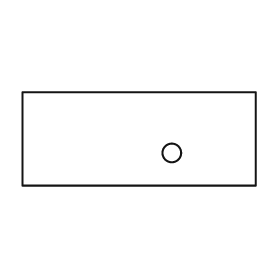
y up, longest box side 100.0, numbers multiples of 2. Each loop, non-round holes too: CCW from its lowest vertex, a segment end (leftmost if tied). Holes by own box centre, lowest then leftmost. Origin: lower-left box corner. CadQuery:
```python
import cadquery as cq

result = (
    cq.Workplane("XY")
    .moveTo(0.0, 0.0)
    .lineTo(100.0, 0.0)
    .lineTo(100.0, 40.0)
    .lineTo(0.0, 40.0)
    .close()
    .moveTo(64.0, 14.0)
    .circle(4.0)
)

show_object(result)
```